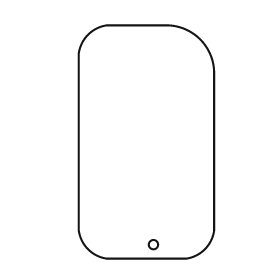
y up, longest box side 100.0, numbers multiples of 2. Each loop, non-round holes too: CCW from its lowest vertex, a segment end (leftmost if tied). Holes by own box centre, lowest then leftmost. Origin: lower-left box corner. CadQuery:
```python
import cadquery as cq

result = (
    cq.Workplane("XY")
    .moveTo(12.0, 0.0)
    .lineTo(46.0, 0.0)
    .threePointArc((54.0, 4.0), (58.0, 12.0))
    .lineTo(58.0, 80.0)
    .threePointArc((52.0, 94.0), (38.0, 100.0))
    .lineTo(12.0, 100.0)
    .threePointArc((4.0, 96.0), (0.0, 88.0))
    .lineTo(0.0, 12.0)
    .threePointArc((4.0, 4.0), (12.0, 0.0))
    .close()
    .moveTo(32.0, 6.0)
    .circle(2.0)
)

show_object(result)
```